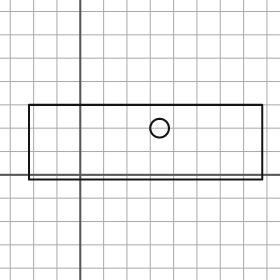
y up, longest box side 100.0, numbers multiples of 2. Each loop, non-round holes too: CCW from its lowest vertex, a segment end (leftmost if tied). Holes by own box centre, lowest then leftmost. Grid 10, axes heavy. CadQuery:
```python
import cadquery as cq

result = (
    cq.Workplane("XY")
    .moveTo(-22.0, -2.0)
    .lineTo(78.0, -2.0)
    .lineTo(78.0, 30.0)
    .lineTo(-22.0, 30.0)
    .close()
    .moveTo(34.0, 20.0)
    .circle(4.0)
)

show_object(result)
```